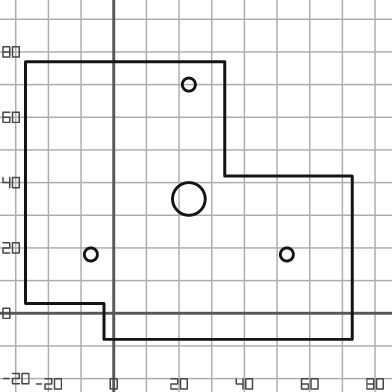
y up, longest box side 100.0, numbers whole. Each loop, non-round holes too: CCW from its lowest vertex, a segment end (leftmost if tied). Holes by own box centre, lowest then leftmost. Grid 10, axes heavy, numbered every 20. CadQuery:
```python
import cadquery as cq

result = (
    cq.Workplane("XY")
    .moveTo(-3.0, -8.0)
    .lineTo(73.0, -8.0)
    .lineTo(73.0, 42.0)
    .lineTo(34.0, 42.0)
    .lineTo(34.0, 77.0)
    .lineTo(-27.0, 77.0)
    .lineTo(-27.0, 3.0)
    .lineTo(-3.0, 3.0)
    .close()
    .moveTo(-7.0, 18.0)
    .circle(2.0)
    .moveTo(53.0, 18.0)
    .circle(2.0)
    .moveTo(23.0, 35.0)
    .circle(5.0)
    .moveTo(23.0, 70.0)
    .circle(2.0)
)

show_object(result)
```